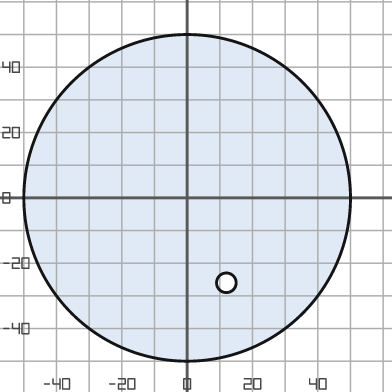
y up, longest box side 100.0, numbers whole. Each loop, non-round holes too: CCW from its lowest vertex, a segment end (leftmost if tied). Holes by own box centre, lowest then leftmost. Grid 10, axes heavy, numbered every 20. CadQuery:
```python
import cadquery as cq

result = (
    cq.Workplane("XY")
    .moveTo(0.0, 0.0)
    .circle(50.0)
    .moveTo(12.0, -26.0)
    .circle(3.0)
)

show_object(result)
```